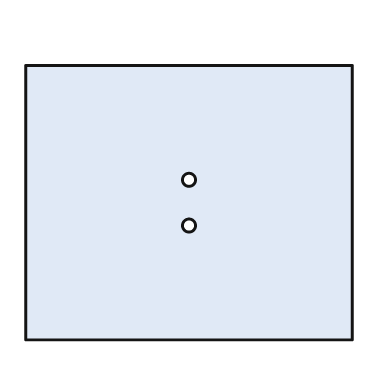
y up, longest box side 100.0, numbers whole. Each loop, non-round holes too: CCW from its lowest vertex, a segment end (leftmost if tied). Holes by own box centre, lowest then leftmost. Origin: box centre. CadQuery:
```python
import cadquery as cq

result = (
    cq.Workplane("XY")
    .moveTo(-50.0, -42.0)
    .lineTo(50.0, -42.0)
    .lineTo(50.0, 42.0)
    .lineTo(-50.0, 42.0)
    .close()
    .moveTo(0.0, -7.0)
    .circle(2.0)
    .moveTo(0.0, 7.0)
    .circle(2.0)
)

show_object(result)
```